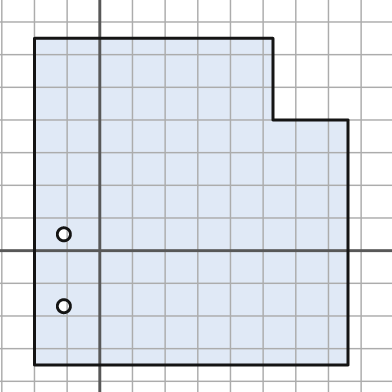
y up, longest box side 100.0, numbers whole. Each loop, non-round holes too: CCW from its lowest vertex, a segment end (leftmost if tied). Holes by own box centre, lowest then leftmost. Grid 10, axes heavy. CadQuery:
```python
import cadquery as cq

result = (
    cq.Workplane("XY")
    .moveTo(-20.0, -35.0)
    .lineTo(76.0, -35.0)
    .lineTo(76.0, 40.0)
    .lineTo(53.0, 40.0)
    .lineTo(53.0, 65.0)
    .lineTo(-20.0, 65.0)
    .close()
    .moveTo(-11.0, -17.0)
    .circle(2.0)
    .moveTo(-11.0, 5.0)
    .circle(2.0)
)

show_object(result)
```